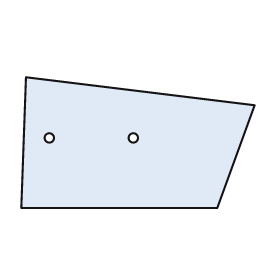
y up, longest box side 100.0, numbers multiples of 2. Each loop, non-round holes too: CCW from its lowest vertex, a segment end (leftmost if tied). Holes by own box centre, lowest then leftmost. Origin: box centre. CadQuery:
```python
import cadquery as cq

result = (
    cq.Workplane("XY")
    .moveTo(-50.0, -28.0)
    .lineTo(34.0, -28.0)
    .lineTo(50.0, 16.0)
    .lineTo(-48.0, 28.0)
    .close()
    .moveTo(-38.0, 2.0)
    .circle(2.0)
    .moveTo(-2.0, 2.0)
    .circle(2.0)
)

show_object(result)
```